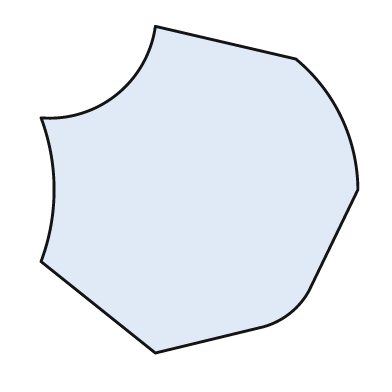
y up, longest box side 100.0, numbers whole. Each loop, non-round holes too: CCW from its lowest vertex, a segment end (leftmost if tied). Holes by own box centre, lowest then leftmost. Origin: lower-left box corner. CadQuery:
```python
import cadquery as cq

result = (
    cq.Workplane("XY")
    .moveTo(35.0, 0.0)
    .lineTo(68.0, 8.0)
    .threePointArc((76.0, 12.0), (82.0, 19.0))
    .lineTo(97.0, 50.0)
    .threePointArc((92.0, 72.0), (78.0, 90.0))
    .lineTo(35.0, 100.0)
    .threePointArc((23.0, 79.0), (0.0, 72.0))
    .threePointArc((4.0, 50.0), (0.0, 28.0))
    .close()
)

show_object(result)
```